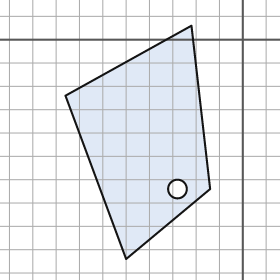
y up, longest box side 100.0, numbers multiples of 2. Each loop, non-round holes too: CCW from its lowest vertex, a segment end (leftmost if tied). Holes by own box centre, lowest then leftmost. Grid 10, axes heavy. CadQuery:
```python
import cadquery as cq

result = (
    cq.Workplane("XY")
    .moveTo(-50.0, -94.0)
    .lineTo(-14.0, -64.0)
    .lineTo(-22.0, 6.0)
    .lineTo(-76.0, -24.0)
    .close()
    .moveTo(-28.0, -64.0)
    .circle(4.0)
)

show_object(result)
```